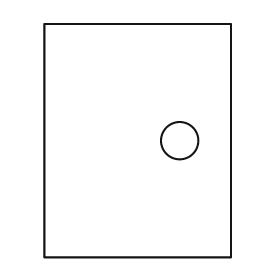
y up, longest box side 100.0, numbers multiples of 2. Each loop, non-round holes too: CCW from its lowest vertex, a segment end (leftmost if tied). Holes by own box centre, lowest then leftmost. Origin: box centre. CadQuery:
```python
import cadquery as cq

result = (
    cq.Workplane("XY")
    .moveTo(-40.0, -50.0)
    .lineTo(40.0, -50.0)
    .lineTo(40.0, 50.0)
    .lineTo(-40.0, 50.0)
    .close()
    .moveTo(18.0, 0.0)
    .circle(8.0)
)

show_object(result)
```